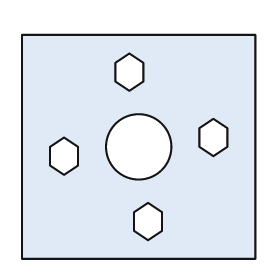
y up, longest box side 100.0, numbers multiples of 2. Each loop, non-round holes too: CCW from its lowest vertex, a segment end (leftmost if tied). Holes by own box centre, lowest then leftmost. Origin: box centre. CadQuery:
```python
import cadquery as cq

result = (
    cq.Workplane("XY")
    .moveTo(-50.0, -48.0)
    .lineTo(50.0, -48.0)
    .lineTo(50.0, 48.0)
    .lineTo(-50.0, 48.0)
    .close()
    .moveTo(4.0, -40.0)
    .lineTo(10.0, -36.0)
    .lineTo(10.0, -28.0)
    .lineTo(4.0, -24.0)
    .lineTo(-2.0, -28.0)
    .lineTo(-2.0, -36.0)
    .close()
    .moveTo(-32.0, -12.0)
    .lineTo(-26.0, -8.0)
    .lineTo(-26.0, 0.0)
    .lineTo(-32.0, 4.0)
    .lineTo(-38.0, 0.0)
    .lineTo(-38.0, -8.0)
    .close()
    .moveTo(0.0, 0.0)
    .circle(14.0)
    .moveTo(32.0, -4.0)
    .lineTo(38.0, 0.0)
    .lineTo(38.0, 8.0)
    .lineTo(32.0, 12.0)
    .lineTo(26.0, 8.0)
    .lineTo(26.0, 0.0)
    .close()
    .moveTo(-4.0, 24.0)
    .lineTo(2.0, 28.0)
    .lineTo(2.0, 36.0)
    .lineTo(-4.0, 40.0)
    .lineTo(-10.0, 36.0)
    .lineTo(-10.0, 28.0)
    .close()
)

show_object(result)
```